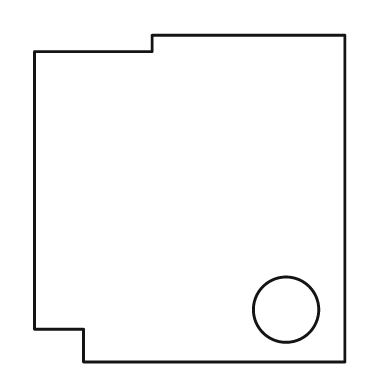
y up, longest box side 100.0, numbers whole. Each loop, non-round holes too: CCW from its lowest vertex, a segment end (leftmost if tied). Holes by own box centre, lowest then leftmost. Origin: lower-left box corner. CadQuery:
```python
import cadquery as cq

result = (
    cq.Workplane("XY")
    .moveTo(15.0, 0.0)
    .lineTo(95.0, 0.0)
    .lineTo(95.0, 100.0)
    .lineTo(36.0, 100.0)
    .lineTo(36.0, 95.0)
    .lineTo(0.0, 95.0)
    .lineTo(0.0, 10.0)
    .lineTo(15.0, 10.0)
    .close()
    .moveTo(77.0, 16.0)
    .circle(10.0)
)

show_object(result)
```